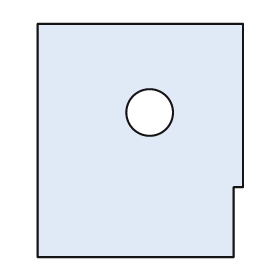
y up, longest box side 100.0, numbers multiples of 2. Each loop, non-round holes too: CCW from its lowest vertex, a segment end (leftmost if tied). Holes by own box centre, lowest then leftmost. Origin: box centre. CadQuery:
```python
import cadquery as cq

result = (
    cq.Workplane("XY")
    .moveTo(-44.0, -50.0)
    .lineTo(40.0, -50.0)
    .lineTo(40.0, -20.0)
    .lineTo(44.0, -20.0)
    .lineTo(44.0, 50.0)
    .lineTo(-44.0, 50.0)
    .close()
    .moveTo(4.0, 12.0)
    .circle(10.0)
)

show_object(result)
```